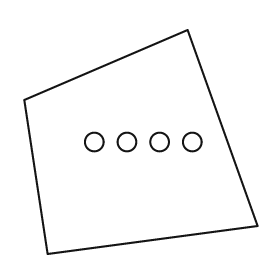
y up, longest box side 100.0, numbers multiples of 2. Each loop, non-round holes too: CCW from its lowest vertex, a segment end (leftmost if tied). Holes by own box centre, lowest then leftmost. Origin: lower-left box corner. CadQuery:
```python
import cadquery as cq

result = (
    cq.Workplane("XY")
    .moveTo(10.0, 0.0)
    .lineTo(100.0, 12.0)
    .lineTo(70.0, 96.0)
    .lineTo(0.0, 66.0)
    .close()
    .moveTo(30.0, 48.0)
    .circle(4.0)
    .moveTo(44.0, 48.0)
    .circle(4.0)
    .moveTo(58.0, 48.0)
    .circle(4.0)
    .moveTo(72.0, 48.0)
    .circle(4.0)
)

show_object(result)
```